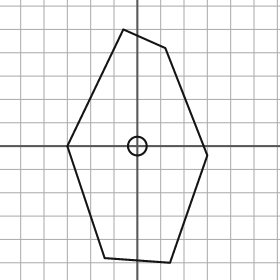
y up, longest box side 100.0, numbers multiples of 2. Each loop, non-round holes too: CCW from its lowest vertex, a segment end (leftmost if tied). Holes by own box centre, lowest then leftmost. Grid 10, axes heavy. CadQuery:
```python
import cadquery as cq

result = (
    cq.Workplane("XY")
    .moveTo(14.0, -50.0)
    .lineTo(30.0, -4.0)
    .lineTo(12.0, 42.0)
    .lineTo(-6.0, 50.0)
    .lineTo(-30.0, 0.0)
    .lineTo(-14.0, -48.0)
    .close()
    .moveTo(0.0, 0.0)
    .circle(4.0)
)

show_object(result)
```